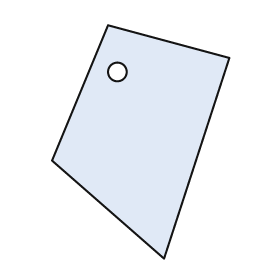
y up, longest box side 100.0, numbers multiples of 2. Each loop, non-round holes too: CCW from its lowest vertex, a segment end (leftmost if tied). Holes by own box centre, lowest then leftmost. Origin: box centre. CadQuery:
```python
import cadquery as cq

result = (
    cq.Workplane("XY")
    .moveTo(10.0, -50.0)
    .lineTo(38.0, 36.0)
    .lineTo(-14.0, 50.0)
    .lineTo(-38.0, -8.0)
    .close()
    .moveTo(-10.0, 30.0)
    .circle(4.0)
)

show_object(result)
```